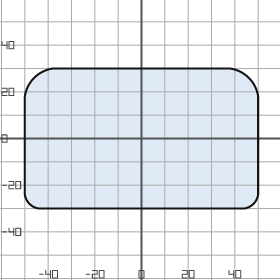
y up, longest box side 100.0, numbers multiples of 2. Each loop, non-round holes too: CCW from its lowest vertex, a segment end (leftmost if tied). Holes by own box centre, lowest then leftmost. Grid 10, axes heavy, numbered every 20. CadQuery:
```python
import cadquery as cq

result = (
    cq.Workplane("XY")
    .moveTo(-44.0, -30.0)
    .lineTo(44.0, -30.0)
    .threePointArc((48.0, -28.0), (50.0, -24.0))
    .lineTo(50.0, 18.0)
    .threePointArc((46.0, 26.0), (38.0, 30.0))
    .lineTo(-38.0, 30.0)
    .threePointArc((-46.0, 26.0), (-50.0, 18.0))
    .lineTo(-50.0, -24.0)
    .threePointArc((-48.0, -28.0), (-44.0, -30.0))
    .close()
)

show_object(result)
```